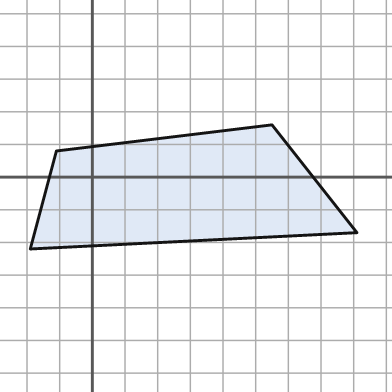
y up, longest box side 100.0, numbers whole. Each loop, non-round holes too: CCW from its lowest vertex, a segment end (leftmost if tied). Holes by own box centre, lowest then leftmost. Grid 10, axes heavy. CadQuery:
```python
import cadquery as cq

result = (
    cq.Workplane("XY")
    .moveTo(-19.0, -22.0)
    .lineTo(81.0, -17.0)
    .lineTo(55.0, 16.0)
    .lineTo(-11.0, 8.0)
    .close()
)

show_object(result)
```